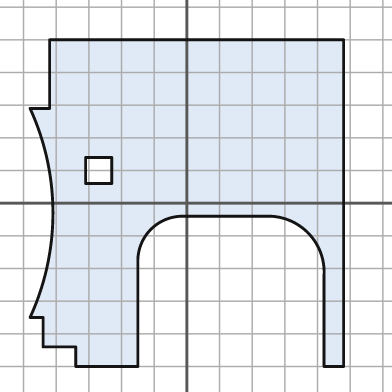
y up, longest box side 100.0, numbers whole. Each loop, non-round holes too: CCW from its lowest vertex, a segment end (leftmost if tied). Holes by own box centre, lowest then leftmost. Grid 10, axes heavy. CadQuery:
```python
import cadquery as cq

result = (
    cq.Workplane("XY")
    .moveTo(-34.0, -50.0)
    .lineTo(-15.0, -50.0)
    .lineTo(-15.0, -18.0)
    .threePointArc((-11.0, -8.0), (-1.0, -4.0))
    .lineTo(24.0, -4.0)
    .threePointArc((37.0, -9.0), (42.0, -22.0))
    .lineTo(42.0, -50.0)
    .lineTo(48.0, -50.0)
    .lineTo(48.0, 50.0)
    .lineTo(-42.0, 50.0)
    .lineTo(-42.0, 29.0)
    .lineTo(-48.0, 29.0)
    .threePointArc((-41.0, -3.0), (-48.0, -35.0))
    .lineTo(-44.0, -35.0)
    .lineTo(-44.0, -44.0)
    .lineTo(-34.0, -44.0)
    .close()
    .moveTo(-31.0, 6.0)
    .lineTo(-23.0, 6.0)
    .lineTo(-23.0, 14.0)
    .lineTo(-31.0, 14.0)
    .close()
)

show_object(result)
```